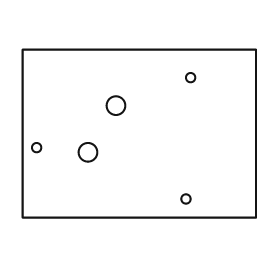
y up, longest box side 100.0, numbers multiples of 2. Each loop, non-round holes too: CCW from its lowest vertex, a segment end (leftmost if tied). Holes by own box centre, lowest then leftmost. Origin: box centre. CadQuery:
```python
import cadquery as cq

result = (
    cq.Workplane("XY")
    .moveTo(-50.0, -36.0)
    .lineTo(50.0, -36.0)
    .lineTo(50.0, 36.0)
    .lineTo(-50.0, 36.0)
    .close()
    .moveTo(20.0, -28.0)
    .circle(2.0)
    .moveTo(-22.0, -8.0)
    .circle(4.0)
    .moveTo(-44.0, -6.0)
    .circle(2.0)
    .moveTo(-10.0, 12.0)
    .circle(4.0)
    .moveTo(22.0, 24.0)
    .circle(2.0)
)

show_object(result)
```